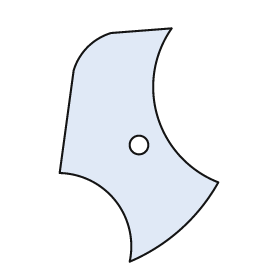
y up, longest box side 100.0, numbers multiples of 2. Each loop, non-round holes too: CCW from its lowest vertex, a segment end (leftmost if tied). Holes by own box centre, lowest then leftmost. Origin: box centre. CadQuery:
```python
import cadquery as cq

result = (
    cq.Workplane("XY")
    .moveTo(-4.0, -50.0)
    .threePointArc((18.0, -36.0), (34.0, -16.0))
    .threePointArc((8.0, 12.0), (14.0, 50.0))
    .lineTo(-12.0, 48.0)
    .threePointArc((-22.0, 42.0), (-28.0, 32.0))
    .lineTo(-34.0, -12.0)
    .threePointArc((-10.0, -24.0), (-4.0, -50.0))
    .close()
    .moveTo(0.0, 0.0)
    .circle(4.0)
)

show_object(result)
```